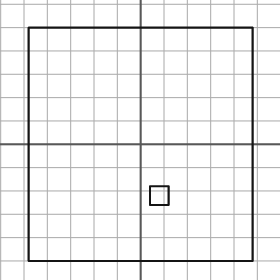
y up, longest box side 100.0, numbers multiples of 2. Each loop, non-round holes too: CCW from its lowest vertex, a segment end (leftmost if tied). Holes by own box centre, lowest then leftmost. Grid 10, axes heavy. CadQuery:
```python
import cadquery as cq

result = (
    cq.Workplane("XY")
    .moveTo(-48.0, -50.0)
    .lineTo(48.0, -50.0)
    .lineTo(48.0, 50.0)
    .lineTo(-48.0, 50.0)
    .close()
    .moveTo(4.0, -26.0)
    .lineTo(12.0, -26.0)
    .lineTo(12.0, -18.0)
    .lineTo(4.0, -18.0)
    .close()
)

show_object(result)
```